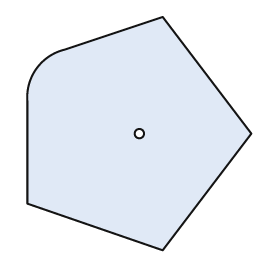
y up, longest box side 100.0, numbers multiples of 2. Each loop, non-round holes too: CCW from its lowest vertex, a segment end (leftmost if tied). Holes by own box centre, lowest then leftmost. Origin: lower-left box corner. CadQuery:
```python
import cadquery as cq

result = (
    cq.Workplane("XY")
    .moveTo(58.0, 0.0)
    .lineTo(96.0, 50.0)
    .lineTo(58.0, 100.0)
    .lineTo(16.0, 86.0)
    .threePointArc((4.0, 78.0), (0.0, 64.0))
    .lineTo(0.0, 20.0)
    .close()
    .moveTo(48.0, 50.0)
    .circle(2.0)
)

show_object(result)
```